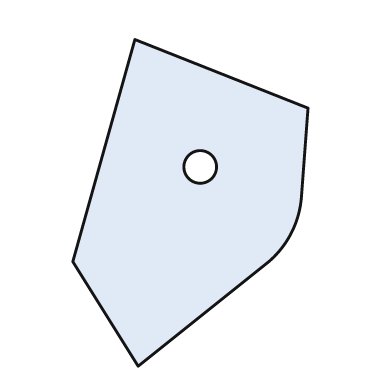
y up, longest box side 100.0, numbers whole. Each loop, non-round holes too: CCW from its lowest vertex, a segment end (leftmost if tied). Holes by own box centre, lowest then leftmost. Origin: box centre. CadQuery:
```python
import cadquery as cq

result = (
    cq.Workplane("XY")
    .moveTo(-16.0, -50.0)
    .lineTo(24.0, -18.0)
    .threePointArc((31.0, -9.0), (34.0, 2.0))
    .lineTo(36.0, 29.0)
    .lineTo(-17.0, 50.0)
    .lineTo(-36.0, -18.0)
    .close()
    .moveTo(3.0, 11.0)
    .circle(5.0)
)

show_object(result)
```